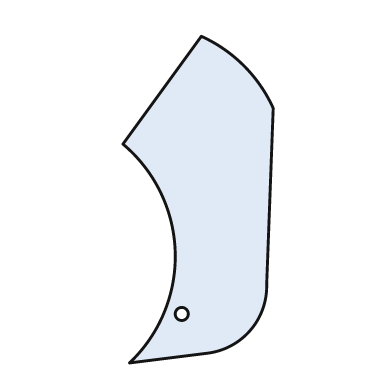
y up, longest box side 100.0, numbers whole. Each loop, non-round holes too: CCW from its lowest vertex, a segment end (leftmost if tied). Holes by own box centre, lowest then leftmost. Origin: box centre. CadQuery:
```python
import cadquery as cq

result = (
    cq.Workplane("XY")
    .moveTo(-21.0, -50.0)
    .lineTo(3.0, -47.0)
    .threePointArc((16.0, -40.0), (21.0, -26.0))
    .lineTo(23.0, 28.0)
    .threePointArc((14.0, 41.0), (1.0, 50.0))
    .lineTo(-23.0, 17.0)
    .threePointArc((-7.0, -16.0), (-21.0, -50.0))
    .close()
    .moveTo(-5.0, -35.0)
    .circle(2.0)
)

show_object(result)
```